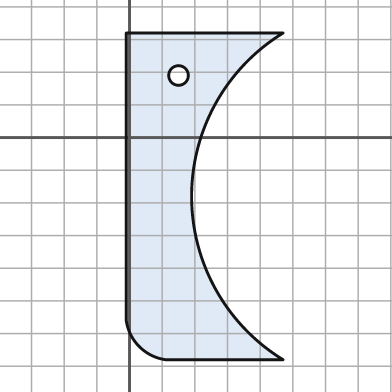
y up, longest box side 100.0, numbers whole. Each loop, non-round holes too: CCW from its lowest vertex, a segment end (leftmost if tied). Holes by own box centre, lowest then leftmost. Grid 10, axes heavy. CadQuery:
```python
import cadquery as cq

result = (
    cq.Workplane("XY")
    .moveTo(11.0, -68.0)
    .lineTo(47.0, -68.0)
    .threePointArc((19.0, -18.0), (47.0, 32.0))
    .lineTo(-1.0, 32.0)
    .lineTo(-1.0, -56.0)
    .threePointArc((3.0, -64.0), (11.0, -68.0))
    .close()
    .moveTo(15.0, 19.0)
    .circle(3.0)
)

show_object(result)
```